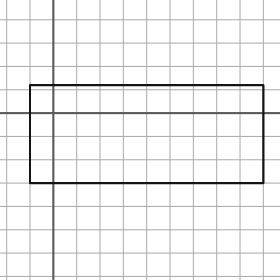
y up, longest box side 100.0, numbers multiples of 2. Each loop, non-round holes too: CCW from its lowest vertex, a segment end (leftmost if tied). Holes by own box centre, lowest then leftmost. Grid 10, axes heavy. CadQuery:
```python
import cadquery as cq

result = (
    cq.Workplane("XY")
    .moveTo(-10.0, -30.0)
    .lineTo(90.0, -30.0)
    .lineTo(90.0, 12.0)
    .lineTo(-10.0, 12.0)
    .close()
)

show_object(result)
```